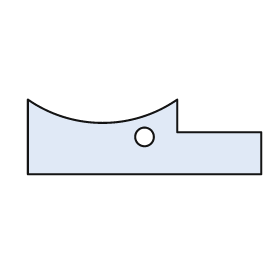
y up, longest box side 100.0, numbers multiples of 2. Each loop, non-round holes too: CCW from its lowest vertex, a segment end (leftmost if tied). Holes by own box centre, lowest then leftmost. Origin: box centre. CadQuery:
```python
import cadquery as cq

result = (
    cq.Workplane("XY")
    .moveTo(-50.0, -16.0)
    .lineTo(50.0, -16.0)
    .lineTo(50.0, 2.0)
    .lineTo(14.0, 2.0)
    .lineTo(14.0, 16.0)
    .threePointArc((-18.0, 6.0), (-50.0, 16.0))
    .close()
    .moveTo(0.0, 0.0)
    .circle(4.0)
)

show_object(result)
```